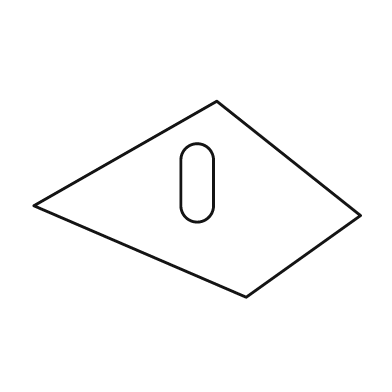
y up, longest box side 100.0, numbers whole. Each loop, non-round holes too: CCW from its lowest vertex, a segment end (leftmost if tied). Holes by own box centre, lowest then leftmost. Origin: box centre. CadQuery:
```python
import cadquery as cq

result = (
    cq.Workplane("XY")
    .moveTo(15.0, -30.0)
    .lineTo(50.0, -5.0)
    .lineTo(6.0, 30.0)
    .lineTo(-50.0, -2.0)
    .close()
    .moveTo(-5.0, -2.0)
    .threePointArc((0.0, -7.0), (5.0, -2.0))
    .lineTo(5.0, 12.0)
    .threePointArc((0.0, 17.0), (-5.0, 12.0))
    .close()
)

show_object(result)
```